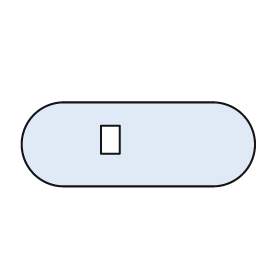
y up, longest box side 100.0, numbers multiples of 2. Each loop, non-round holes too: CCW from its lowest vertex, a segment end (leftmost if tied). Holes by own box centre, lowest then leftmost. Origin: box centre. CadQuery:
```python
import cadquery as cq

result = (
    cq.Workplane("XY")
    .moveTo(-32.0, -18.0)
    .lineTo(32.0, -18.0)
    .threePointArc((50.0, 0.0), (32.0, 18.0))
    .lineTo(-32.0, 18.0)
    .threePointArc((-50.0, 0.0), (-32.0, -18.0))
    .close()
    .moveTo(-16.0, -4.0)
    .lineTo(-8.0, -4.0)
    .lineTo(-8.0, 8.0)
    .lineTo(-16.0, 8.0)
    .close()
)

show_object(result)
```